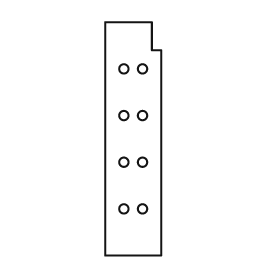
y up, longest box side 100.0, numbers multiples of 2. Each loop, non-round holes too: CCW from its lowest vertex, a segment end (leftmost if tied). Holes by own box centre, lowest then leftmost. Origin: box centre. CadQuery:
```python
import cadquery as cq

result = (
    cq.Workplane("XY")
    .moveTo(-12.0, -50.0)
    .lineTo(12.0, -50.0)
    .lineTo(12.0, 38.0)
    .lineTo(8.0, 38.0)
    .lineTo(8.0, 50.0)
    .lineTo(-12.0, 50.0)
    .close()
    .moveTo(-4.0, -30.0)
    .circle(2.0)
    .moveTo(4.0, -30.0)
    .circle(2.0)
    .moveTo(-4.0, -10.0)
    .circle(2.0)
    .moveTo(4.0, -10.0)
    .circle(2.0)
    .moveTo(-4.0, 10.0)
    .circle(2.0)
    .moveTo(4.0, 10.0)
    .circle(2.0)
    .moveTo(-4.0, 30.0)
    .circle(2.0)
    .moveTo(4.0, 30.0)
    .circle(2.0)
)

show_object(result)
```